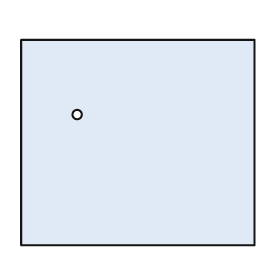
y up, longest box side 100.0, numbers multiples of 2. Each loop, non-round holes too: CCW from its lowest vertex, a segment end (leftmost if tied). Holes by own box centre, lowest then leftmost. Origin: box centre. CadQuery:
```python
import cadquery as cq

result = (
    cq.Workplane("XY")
    .moveTo(-50.0, -44.0)
    .lineTo(50.0, -44.0)
    .lineTo(50.0, 44.0)
    .lineTo(-50.0, 44.0)
    .close()
    .moveTo(-26.0, 12.0)
    .circle(2.0)
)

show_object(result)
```